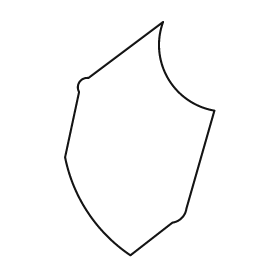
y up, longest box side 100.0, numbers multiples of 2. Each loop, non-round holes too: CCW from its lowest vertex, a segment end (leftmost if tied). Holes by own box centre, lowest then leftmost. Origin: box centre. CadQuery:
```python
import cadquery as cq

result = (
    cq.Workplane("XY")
    .moveTo(-4.0, -50.0)
    .lineTo(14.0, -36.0)
    .threePointArc((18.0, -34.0), (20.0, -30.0))
    .lineTo(32.0, 12.0)
    .threePointArc((12.0, 26.0), (10.0, 50.0))
    .lineTo(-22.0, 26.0)
    .threePointArc((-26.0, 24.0), (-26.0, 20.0))
    .lineTo(-32.0, -8.0)
    .threePointArc((-22.0, -32.0), (-4.0, -50.0))
    .close()
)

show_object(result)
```